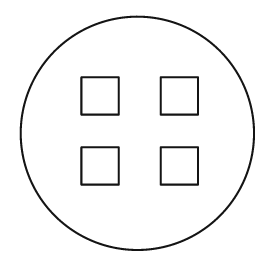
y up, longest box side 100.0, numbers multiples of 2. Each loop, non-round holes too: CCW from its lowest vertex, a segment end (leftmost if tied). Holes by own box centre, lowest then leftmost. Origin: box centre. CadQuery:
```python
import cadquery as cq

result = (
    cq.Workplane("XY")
    .moveTo(0.0, 0.0)
    .circle(50.0)
    .moveTo(-24.0, -22.0)
    .lineTo(-8.0, -22.0)
    .lineTo(-8.0, -6.0)
    .lineTo(-24.0, -6.0)
    .close()
    .moveTo(10.0, -22.0)
    .lineTo(26.0, -22.0)
    .lineTo(26.0, -6.0)
    .lineTo(10.0, -6.0)
    .close()
    .moveTo(-24.0, 8.0)
    .lineTo(-8.0, 8.0)
    .lineTo(-8.0, 24.0)
    .lineTo(-24.0, 24.0)
    .close()
    .moveTo(10.0, 8.0)
    .lineTo(26.0, 8.0)
    .lineTo(26.0, 24.0)
    .lineTo(10.0, 24.0)
    .close()
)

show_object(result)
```